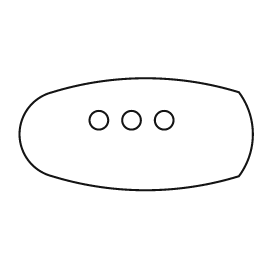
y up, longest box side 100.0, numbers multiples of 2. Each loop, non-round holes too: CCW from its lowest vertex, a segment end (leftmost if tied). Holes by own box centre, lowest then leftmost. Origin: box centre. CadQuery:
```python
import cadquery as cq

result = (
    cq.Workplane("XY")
    .moveTo(-36.0, -18.0)
    .threePointArc((4.0, -24.0), (44.0, -18.0))
    .threePointArc((50.0, 0.0), (44.0, 18.0))
    .threePointArc((4.0, 24.0), (-36.0, 18.0))
    .threePointArc((-50.0, 0.0), (-36.0, -18.0))
    .close()
    .moveTo(-16.0, 6.0)
    .circle(4.0)
    .moveTo(-2.0, 6.0)
    .circle(4.0)
    .moveTo(12.0, 6.0)
    .circle(4.0)
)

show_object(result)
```